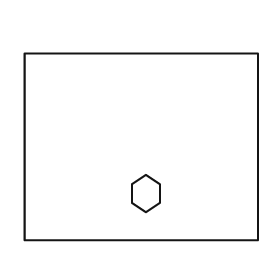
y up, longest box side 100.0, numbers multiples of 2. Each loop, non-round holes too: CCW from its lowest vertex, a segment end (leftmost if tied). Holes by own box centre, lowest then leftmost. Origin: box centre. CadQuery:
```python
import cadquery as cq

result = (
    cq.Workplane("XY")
    .moveTo(-50.0, -40.0)
    .lineTo(50.0, -40.0)
    .lineTo(50.0, 40.0)
    .lineTo(-50.0, 40.0)
    .close()
    .moveTo(2.0, -28.0)
    .lineTo(8.0, -24.0)
    .lineTo(8.0, -16.0)
    .lineTo(2.0, -12.0)
    .lineTo(-4.0, -16.0)
    .lineTo(-4.0, -24.0)
    .close()
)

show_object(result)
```